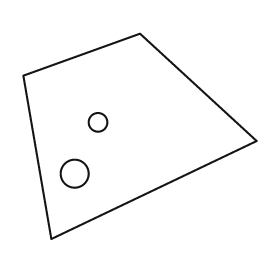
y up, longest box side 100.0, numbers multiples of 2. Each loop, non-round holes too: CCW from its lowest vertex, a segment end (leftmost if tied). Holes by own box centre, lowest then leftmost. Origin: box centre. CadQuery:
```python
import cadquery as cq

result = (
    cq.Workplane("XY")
    .moveTo(-38.0, -44.0)
    .lineTo(50.0, -2.0)
    .lineTo(0.0, 44.0)
    .lineTo(-50.0, 26.0)
    .close()
    .moveTo(-28.0, -16.0)
    .circle(6.0)
    .moveTo(-18.0, 6.0)
    .circle(4.0)
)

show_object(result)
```